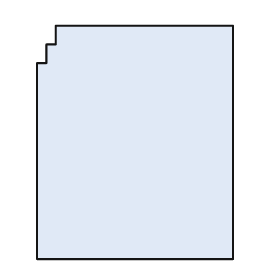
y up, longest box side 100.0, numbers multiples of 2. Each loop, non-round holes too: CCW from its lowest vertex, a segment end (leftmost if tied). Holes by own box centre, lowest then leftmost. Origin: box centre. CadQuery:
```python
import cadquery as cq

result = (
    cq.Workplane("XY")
    .moveTo(-42.0, -50.0)
    .lineTo(42.0, -50.0)
    .lineTo(42.0, 50.0)
    .lineTo(-34.0, 50.0)
    .lineTo(-34.0, 42.0)
    .lineTo(-38.0, 42.0)
    .lineTo(-38.0, 34.0)
    .lineTo(-42.0, 34.0)
    .close()
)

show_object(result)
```